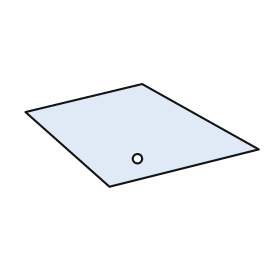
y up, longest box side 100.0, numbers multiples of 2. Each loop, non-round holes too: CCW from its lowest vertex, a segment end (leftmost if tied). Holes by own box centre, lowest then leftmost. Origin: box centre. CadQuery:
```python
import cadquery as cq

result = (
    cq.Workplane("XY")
    .moveTo(-14.0, -22.0)
    .lineTo(50.0, -6.0)
    .lineTo(0.0, 22.0)
    .lineTo(-50.0, 10.0)
    .close()
    .moveTo(-2.0, -10.0)
    .circle(2.0)
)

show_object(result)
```